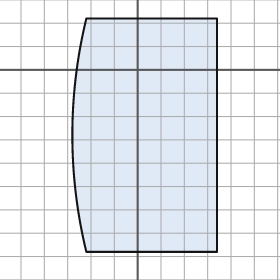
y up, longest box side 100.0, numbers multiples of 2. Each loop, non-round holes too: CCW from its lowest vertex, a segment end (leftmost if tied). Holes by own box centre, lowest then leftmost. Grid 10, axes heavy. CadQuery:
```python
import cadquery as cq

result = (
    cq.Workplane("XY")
    .moveTo(-22.0, -78.0)
    .lineTo(34.0, -78.0)
    .lineTo(34.0, 22.0)
    .lineTo(-22.0, 22.0)
    .threePointArc((-28.0, -28.0), (-22.0, -78.0))
    .close()
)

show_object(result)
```